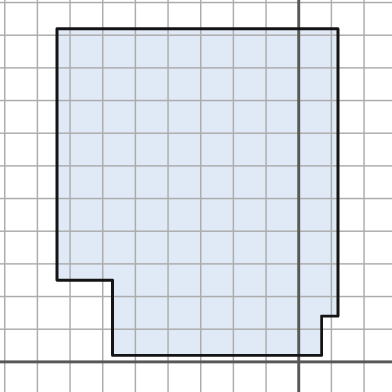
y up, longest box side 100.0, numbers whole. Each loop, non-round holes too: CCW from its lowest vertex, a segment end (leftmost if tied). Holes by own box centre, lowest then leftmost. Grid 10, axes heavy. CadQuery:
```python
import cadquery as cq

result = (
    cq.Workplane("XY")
    .moveTo(-57.0, 2.0)
    .lineTo(7.0, 2.0)
    .lineTo(7.0, 14.0)
    .lineTo(12.0, 14.0)
    .lineTo(12.0, 102.0)
    .lineTo(-74.0, 102.0)
    .lineTo(-74.0, 25.0)
    .lineTo(-57.0, 25.0)
    .close()
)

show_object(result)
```